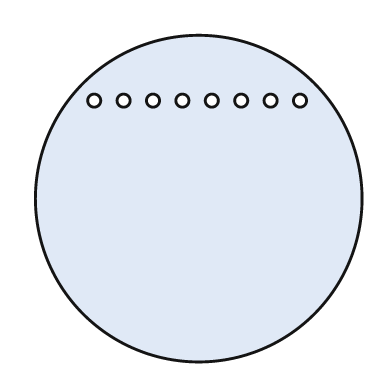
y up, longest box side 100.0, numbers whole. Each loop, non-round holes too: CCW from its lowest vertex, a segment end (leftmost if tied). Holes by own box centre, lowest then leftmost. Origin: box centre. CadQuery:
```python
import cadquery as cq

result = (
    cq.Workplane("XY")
    .moveTo(0.0, 0.0)
    .circle(50.0)
    .moveTo(-32.0, 30.0)
    .circle(2.0)
    .moveTo(-23.0, 30.0)
    .circle(2.0)
    .moveTo(-14.0, 30.0)
    .circle(2.0)
    .moveTo(-5.0, 30.0)
    .circle(2.0)
    .moveTo(4.0, 30.0)
    .circle(2.0)
    .moveTo(13.0, 30.0)
    .circle(2.0)
    .moveTo(22.0, 30.0)
    .circle(2.0)
    .moveTo(31.0, 30.0)
    .circle(2.0)
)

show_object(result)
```